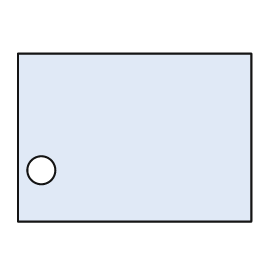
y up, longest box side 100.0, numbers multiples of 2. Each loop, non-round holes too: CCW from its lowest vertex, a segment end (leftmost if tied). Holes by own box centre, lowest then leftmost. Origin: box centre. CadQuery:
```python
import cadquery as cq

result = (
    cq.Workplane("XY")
    .moveTo(-50.0, -36.0)
    .lineTo(50.0, -36.0)
    .lineTo(50.0, 36.0)
    .lineTo(-50.0, 36.0)
    .close()
    .moveTo(-40.0, -14.0)
    .circle(6.0)
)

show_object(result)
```